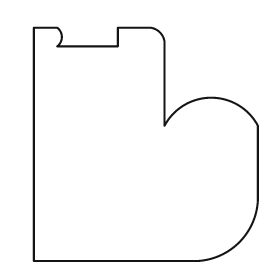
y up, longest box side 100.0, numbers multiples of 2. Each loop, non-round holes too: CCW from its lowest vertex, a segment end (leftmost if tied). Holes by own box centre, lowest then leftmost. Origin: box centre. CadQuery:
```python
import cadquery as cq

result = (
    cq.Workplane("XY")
    .moveTo(-48.0, -50.0)
    .lineTo(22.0, -50.0)
    .threePointArc((40.0, -42.0), (48.0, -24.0))
    .lineTo(48.0, 8.0)
    .threePointArc((28.0, 20.0), (8.0, 8.0))
    .lineTo(8.0, 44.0)
    .threePointArc((6.0, 48.0), (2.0, 50.0))
    .lineTo(-12.0, 50.0)
    .lineTo(-12.0, 42.0)
    .lineTo(-38.0, 42.0)
    .threePointArc((-36.0, 46.0), (-38.0, 50.0))
    .lineTo(-48.0, 50.0)
    .close()
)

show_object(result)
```